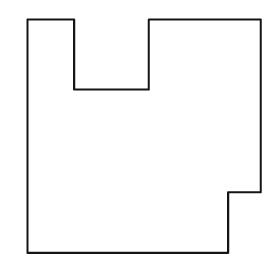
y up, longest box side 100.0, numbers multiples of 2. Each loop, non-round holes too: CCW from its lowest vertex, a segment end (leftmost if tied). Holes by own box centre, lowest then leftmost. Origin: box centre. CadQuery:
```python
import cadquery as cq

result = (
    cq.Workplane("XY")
    .moveTo(-50.0, -50.0)
    .lineTo(36.0, -50.0)
    .lineTo(36.0, -24.0)
    .lineTo(50.0, -24.0)
    .lineTo(50.0, 50.0)
    .lineTo(2.0, 50.0)
    .lineTo(2.0, 20.0)
    .lineTo(-30.0, 20.0)
    .lineTo(-30.0, 50.0)
    .lineTo(-50.0, 50.0)
    .close()
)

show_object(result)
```